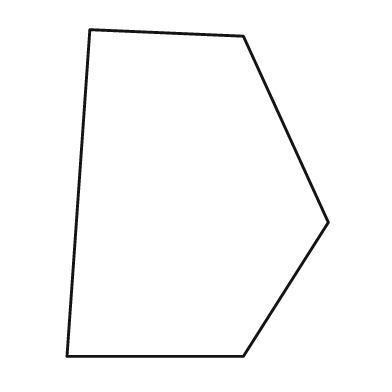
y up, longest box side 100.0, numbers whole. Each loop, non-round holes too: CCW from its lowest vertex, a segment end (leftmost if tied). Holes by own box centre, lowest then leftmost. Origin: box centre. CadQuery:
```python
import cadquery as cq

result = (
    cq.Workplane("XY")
    .moveTo(-40.0, -50.0)
    .lineTo(14.0, -50.0)
    .lineTo(40.0, -9.0)
    .lineTo(14.0, 48.0)
    .lineTo(-33.0, 50.0)
    .close()
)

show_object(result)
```